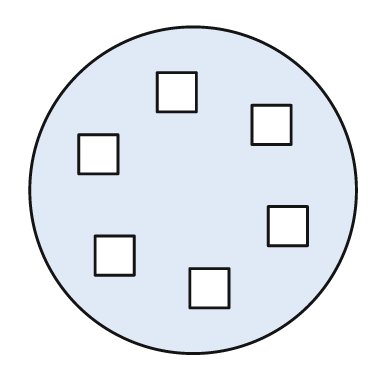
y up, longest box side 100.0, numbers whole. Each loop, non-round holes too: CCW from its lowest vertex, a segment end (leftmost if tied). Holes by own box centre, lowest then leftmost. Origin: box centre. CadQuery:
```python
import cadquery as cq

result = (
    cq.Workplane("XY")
    .moveTo(0.0, 0.0)
    .circle(50.0)
    .moveTo(-1.0, -36.0)
    .lineTo(11.0, -36.0)
    .lineTo(11.0, -24.0)
    .lineTo(-1.0, -24.0)
    .close()
    .moveTo(-30.0, -26.0)
    .lineTo(-18.0, -26.0)
    .lineTo(-18.0, -14.0)
    .lineTo(-30.0, -14.0)
    .close()
    .moveTo(23.0, -17.0)
    .lineTo(35.0, -17.0)
    .lineTo(35.0, -5.0)
    .lineTo(23.0, -5.0)
    .close()
    .moveTo(-35.0, 5.0)
    .lineTo(-23.0, 5.0)
    .lineTo(-23.0, 17.0)
    .lineTo(-35.0, 17.0)
    .close()
    .moveTo(18.0, 14.0)
    .lineTo(30.0, 14.0)
    .lineTo(30.0, 26.0)
    .lineTo(18.0, 26.0)
    .close()
    .moveTo(-11.0, 24.0)
    .lineTo(1.0, 24.0)
    .lineTo(1.0, 36.0)
    .lineTo(-11.0, 36.0)
    .close()
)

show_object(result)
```